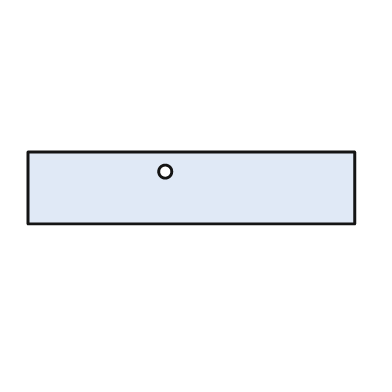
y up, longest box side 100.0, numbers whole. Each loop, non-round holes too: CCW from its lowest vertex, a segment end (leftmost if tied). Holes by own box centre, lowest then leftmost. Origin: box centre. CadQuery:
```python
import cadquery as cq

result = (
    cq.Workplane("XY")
    .moveTo(-50.0, -11.0)
    .lineTo(50.0, -11.0)
    .lineTo(50.0, 11.0)
    .lineTo(-50.0, 11.0)
    .close()
    .moveTo(-8.0, 5.0)
    .circle(2.0)
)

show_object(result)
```